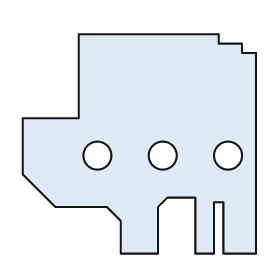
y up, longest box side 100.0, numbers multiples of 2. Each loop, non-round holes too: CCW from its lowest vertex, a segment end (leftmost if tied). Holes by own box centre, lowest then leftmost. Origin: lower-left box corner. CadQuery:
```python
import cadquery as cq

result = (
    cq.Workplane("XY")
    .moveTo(42.0, 0.0)
    .lineTo(58.0, 0.0)
    .lineTo(58.0, 20.0)
    .lineTo(62.0, 24.0)
    .lineTo(74.0, 24.0)
    .lineTo(74.0, 0.0)
    .lineTo(82.0, 0.0)
    .lineTo(82.0, 22.0)
    .lineTo(86.0, 22.0)
    .lineTo(86.0, 0.0)
    .lineTo(100.0, 0.0)
    .lineTo(100.0, 86.0)
    .lineTo(94.0, 86.0)
    .lineTo(94.0, 90.0)
    .lineTo(84.0, 90.0)
    .lineTo(84.0, 94.0)
    .lineTo(24.0, 94.0)
    .lineTo(24.0, 58.0)
    .lineTo(0.0, 58.0)
    .lineTo(0.0, 34.0)
    .lineTo(14.0, 20.0)
    .lineTo(36.0, 20.0)
    .lineTo(42.0, 14.0)
    .close()
    .moveTo(32.0, 42.0)
    .circle(6.0)
    .moveTo(60.0, 42.0)
    .circle(6.0)
    .moveTo(88.0, 42.0)
    .circle(6.0)
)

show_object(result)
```